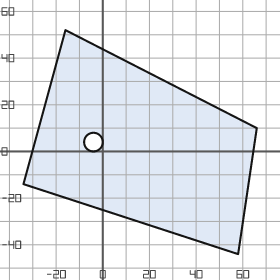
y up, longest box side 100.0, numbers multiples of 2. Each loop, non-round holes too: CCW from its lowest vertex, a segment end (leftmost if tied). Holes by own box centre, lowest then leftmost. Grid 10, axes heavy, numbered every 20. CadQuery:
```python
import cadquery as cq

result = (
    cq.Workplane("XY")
    .moveTo(58.0, -44.0)
    .lineTo(66.0, 10.0)
    .lineTo(-16.0, 52.0)
    .lineTo(-34.0, -14.0)
    .close()
    .moveTo(-4.0, 4.0)
    .circle(4.0)
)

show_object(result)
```